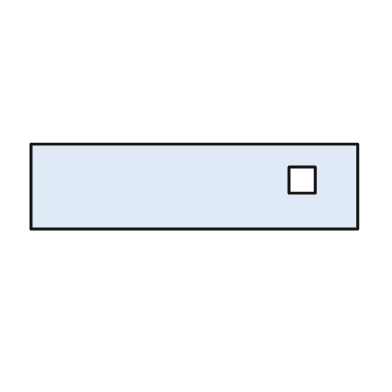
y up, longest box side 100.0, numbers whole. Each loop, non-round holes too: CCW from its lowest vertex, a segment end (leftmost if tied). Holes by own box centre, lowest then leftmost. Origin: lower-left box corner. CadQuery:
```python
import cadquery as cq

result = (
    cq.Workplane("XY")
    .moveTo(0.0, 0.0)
    .lineTo(100.0, 0.0)
    .lineTo(100.0, 26.0)
    .lineTo(0.0, 26.0)
    .close()
    .moveTo(79.0, 11.0)
    .lineTo(87.0, 11.0)
    .lineTo(87.0, 19.0)
    .lineTo(79.0, 19.0)
    .close()
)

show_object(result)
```